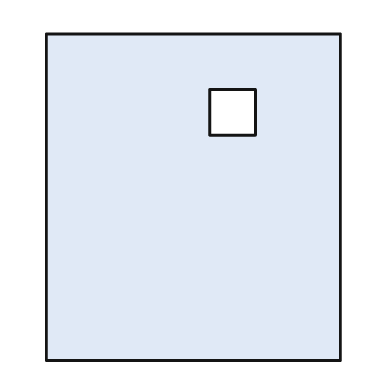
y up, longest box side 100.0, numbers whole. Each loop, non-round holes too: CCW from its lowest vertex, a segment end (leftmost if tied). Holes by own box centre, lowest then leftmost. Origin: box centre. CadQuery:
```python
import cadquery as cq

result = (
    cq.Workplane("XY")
    .moveTo(-45.0, -50.0)
    .lineTo(45.0, -50.0)
    .lineTo(45.0, 50.0)
    .lineTo(-45.0, 50.0)
    .close()
    .moveTo(5.0, 19.0)
    .lineTo(19.0, 19.0)
    .lineTo(19.0, 33.0)
    .lineTo(5.0, 33.0)
    .close()
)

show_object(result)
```